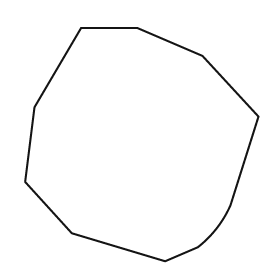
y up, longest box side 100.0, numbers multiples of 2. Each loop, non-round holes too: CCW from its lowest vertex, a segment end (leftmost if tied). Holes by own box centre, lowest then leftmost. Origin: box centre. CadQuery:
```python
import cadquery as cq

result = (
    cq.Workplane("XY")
    .moveTo(10.0, -50.0)
    .lineTo(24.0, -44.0)
    .threePointArc((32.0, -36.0), (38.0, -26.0))
    .lineTo(50.0, 12.0)
    .lineTo(26.0, 38.0)
    .lineTo(-2.0, 50.0)
    .lineTo(-26.0, 50.0)
    .lineTo(-46.0, 16.0)
    .lineTo(-50.0, -16.0)
    .lineTo(-30.0, -38.0)
    .close()
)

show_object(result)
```